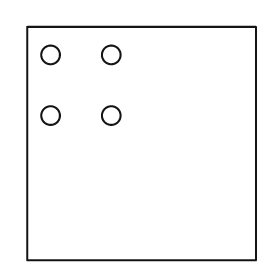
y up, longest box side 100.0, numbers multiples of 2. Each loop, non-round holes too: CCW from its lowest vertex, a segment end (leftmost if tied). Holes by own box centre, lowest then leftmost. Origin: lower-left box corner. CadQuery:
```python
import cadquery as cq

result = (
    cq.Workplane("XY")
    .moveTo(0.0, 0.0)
    .lineTo(98.0, 0.0)
    .lineTo(98.0, 100.0)
    .lineTo(0.0, 100.0)
    .close()
    .moveTo(10.0, 62.0)
    .circle(4.0)
    .moveTo(36.0, 62.0)
    .circle(4.0)
    .moveTo(10.0, 88.0)
    .circle(4.0)
    .moveTo(36.0, 88.0)
    .circle(4.0)
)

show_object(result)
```